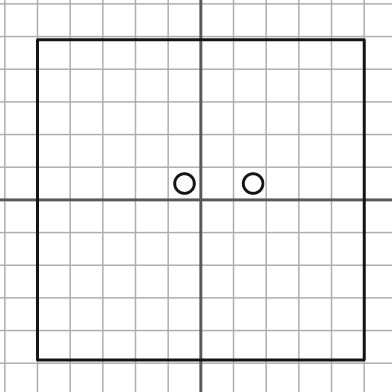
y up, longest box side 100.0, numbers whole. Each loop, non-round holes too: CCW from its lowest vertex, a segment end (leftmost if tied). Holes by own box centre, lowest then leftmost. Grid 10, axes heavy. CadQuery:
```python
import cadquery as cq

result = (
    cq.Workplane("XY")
    .moveTo(-50.0, -49.0)
    .lineTo(50.0, -49.0)
    .lineTo(50.0, 49.0)
    .lineTo(-50.0, 49.0)
    .close()
    .moveTo(-5.0, 5.0)
    .circle(3.0)
    .moveTo(16.0, 5.0)
    .circle(3.0)
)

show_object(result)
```